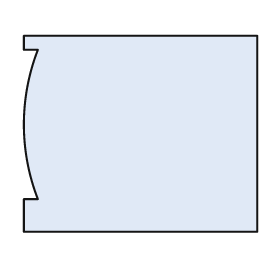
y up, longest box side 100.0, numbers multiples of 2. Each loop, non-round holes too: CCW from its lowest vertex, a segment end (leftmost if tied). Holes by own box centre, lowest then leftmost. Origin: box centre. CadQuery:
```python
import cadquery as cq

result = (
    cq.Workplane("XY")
    .moveTo(-50.0, -42.0)
    .lineTo(50.0, -42.0)
    .lineTo(50.0, 42.0)
    .lineTo(-50.0, 42.0)
    .lineTo(-50.0, 36.0)
    .lineTo(-44.0, 36.0)
    .threePointArc((-50.0, 4.0), (-44.0, -28.0))
    .lineTo(-50.0, -28.0)
    .close()
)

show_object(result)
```